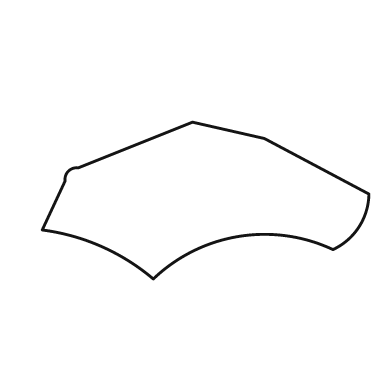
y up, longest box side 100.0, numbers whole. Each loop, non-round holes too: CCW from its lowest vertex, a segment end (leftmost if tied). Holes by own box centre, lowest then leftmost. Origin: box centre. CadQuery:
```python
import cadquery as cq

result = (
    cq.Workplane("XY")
    .moveTo(-16.0, -24.0)
    .threePointArc((10.0, -11.0), (39.0, -15.0))
    .threePointArc((47.0, -8.0), (50.0, 2.0))
    .lineTo(18.0, 19.0)
    .lineTo(-4.0, 24.0)
    .lineTo(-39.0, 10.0)
    .threePointArc((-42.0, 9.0), (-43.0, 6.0))
    .lineTo(-50.0, -9.0)
    .threePointArc((-32.0, -14.0), (-16.0, -24.0))
    .close()
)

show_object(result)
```